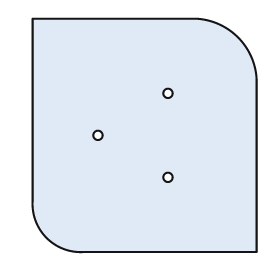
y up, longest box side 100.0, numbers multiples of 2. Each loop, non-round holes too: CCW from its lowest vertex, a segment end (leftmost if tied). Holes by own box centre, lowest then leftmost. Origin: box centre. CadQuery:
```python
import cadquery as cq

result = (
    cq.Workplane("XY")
    .moveTo(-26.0, -50.0)
    .lineTo(48.0, -50.0)
    .lineTo(48.0, 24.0)
    .threePointArc((40.0, 42.0), (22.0, 50.0))
    .lineTo(-48.0, 50.0)
    .lineTo(-48.0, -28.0)
    .threePointArc((-42.0, -44.0), (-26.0, -50.0))
    .close()
    .moveTo(10.0, -18.0)
    .circle(2.0)
    .moveTo(-20.0, 0.0)
    .circle(2.0)
    .moveTo(10.0, 18.0)
    .circle(2.0)
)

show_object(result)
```